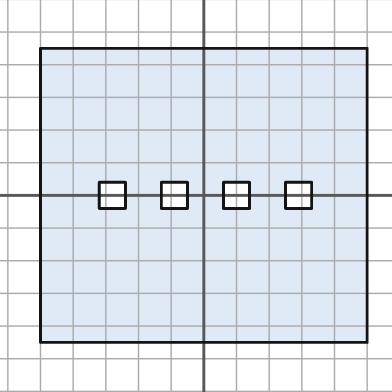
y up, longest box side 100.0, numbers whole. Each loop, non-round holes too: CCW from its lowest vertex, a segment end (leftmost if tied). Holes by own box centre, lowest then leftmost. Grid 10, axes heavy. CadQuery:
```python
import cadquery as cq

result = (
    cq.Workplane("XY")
    .moveTo(-50.0, -45.0)
    .lineTo(50.0, -45.0)
    .lineTo(50.0, 45.0)
    .lineTo(-50.0, 45.0)
    .close()
    .moveTo(-32.0, -4.0)
    .lineTo(-24.0, -4.0)
    .lineTo(-24.0, 4.0)
    .lineTo(-32.0, 4.0)
    .close()
    .moveTo(-13.0, -4.0)
    .lineTo(-5.0, -4.0)
    .lineTo(-5.0, 4.0)
    .lineTo(-13.0, 4.0)
    .close()
    .moveTo(6.0, -4.0)
    .lineTo(14.0, -4.0)
    .lineTo(14.0, 4.0)
    .lineTo(6.0, 4.0)
    .close()
    .moveTo(25.0, -4.0)
    .lineTo(33.0, -4.0)
    .lineTo(33.0, 4.0)
    .lineTo(25.0, 4.0)
    .close()
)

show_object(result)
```